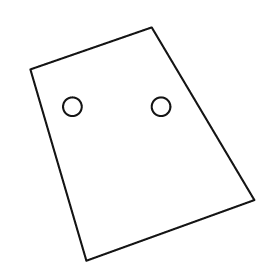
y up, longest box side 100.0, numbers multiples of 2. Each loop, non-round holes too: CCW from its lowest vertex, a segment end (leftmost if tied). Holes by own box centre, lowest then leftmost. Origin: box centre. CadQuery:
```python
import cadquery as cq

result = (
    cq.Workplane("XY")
    .moveTo(-24.0, -50.0)
    .lineTo(48.0, -24.0)
    .lineTo(4.0, 50.0)
    .lineTo(-48.0, 32.0)
    .close()
    .moveTo(-30.0, 16.0)
    .circle(4.0)
    .moveTo(8.0, 16.0)
    .circle(4.0)
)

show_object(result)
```